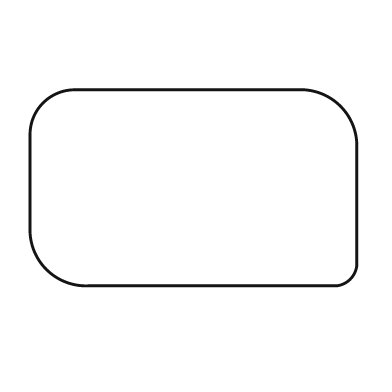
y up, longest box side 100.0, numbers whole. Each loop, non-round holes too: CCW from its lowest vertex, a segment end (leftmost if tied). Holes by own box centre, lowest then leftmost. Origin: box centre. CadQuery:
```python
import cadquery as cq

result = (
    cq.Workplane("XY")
    .moveTo(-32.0, -30.0)
    .lineTo(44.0, -30.0)
    .threePointArc((48.0, -28.0), (50.0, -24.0))
    .lineTo(50.0, 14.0)
    .threePointArc((45.0, 25.0), (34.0, 30.0))
    .lineTo(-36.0, 30.0)
    .threePointArc((-46.0, 26.0), (-50.0, 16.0))
    .lineTo(-50.0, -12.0)
    .threePointArc((-45.0, -25.0), (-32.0, -30.0))
    .close()
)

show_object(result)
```